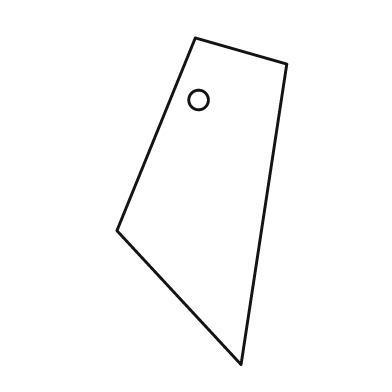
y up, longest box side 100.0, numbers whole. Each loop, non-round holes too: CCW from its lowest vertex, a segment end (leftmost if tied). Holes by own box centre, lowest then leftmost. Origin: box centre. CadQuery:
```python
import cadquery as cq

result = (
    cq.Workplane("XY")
    .moveTo(12.0, -50.0)
    .lineTo(26.0, 42.0)
    .lineTo(-2.0, 50.0)
    .lineTo(-26.0, -9.0)
    .close()
    .moveTo(-1.0, 31.0)
    .circle(3.0)
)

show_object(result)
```